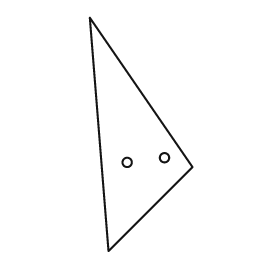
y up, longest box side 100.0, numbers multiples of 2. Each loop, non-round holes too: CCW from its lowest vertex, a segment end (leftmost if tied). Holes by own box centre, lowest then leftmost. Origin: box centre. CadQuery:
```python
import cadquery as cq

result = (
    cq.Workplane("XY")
    .moveTo(-14.0, -50.0)
    .lineTo(22.0, -14.0)
    .lineTo(-22.0, 50.0)
    .close()
    .moveTo(-6.0, -12.0)
    .circle(2.0)
    .moveTo(10.0, -10.0)
    .circle(2.0)
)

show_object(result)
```